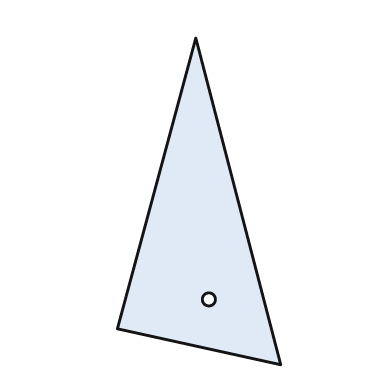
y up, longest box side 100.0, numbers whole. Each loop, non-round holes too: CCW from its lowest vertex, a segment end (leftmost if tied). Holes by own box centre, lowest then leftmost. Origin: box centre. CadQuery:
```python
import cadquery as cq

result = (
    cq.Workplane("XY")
    .moveTo(25.0, -50.0)
    .lineTo(-1.0, 50.0)
    .lineTo(-25.0, -39.0)
    .close()
    .moveTo(3.0, -30.0)
    .circle(2.0)
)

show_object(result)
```